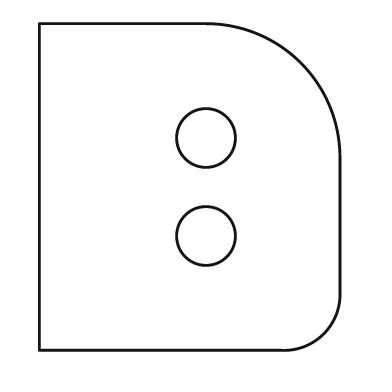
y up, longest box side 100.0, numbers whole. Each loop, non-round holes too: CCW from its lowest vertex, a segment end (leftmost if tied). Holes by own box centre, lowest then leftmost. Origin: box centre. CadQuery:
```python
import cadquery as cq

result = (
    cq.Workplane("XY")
    .moveTo(-46.0, -50.0)
    .lineTo(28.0, -50.0)
    .threePointArc((41.0, -45.0), (46.0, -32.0))
    .lineTo(46.0, 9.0)
    .threePointArc((34.0, 38.0), (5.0, 50.0))
    .lineTo(-46.0, 50.0)
    .close()
    .moveTo(5.0, -15.0)
    .circle(9.0)
    .moveTo(5.0, 15.0)
    .circle(9.0)
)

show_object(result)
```